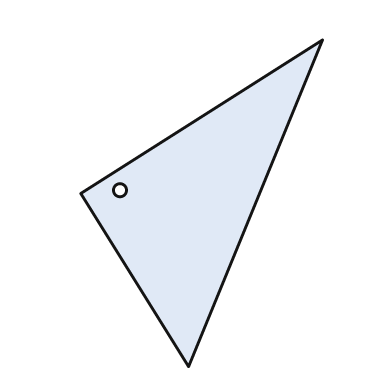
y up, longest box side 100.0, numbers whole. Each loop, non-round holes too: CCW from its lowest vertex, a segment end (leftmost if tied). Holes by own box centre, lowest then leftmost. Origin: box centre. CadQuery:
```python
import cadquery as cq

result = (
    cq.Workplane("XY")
    .moveTo(-4.0, -50.0)
    .lineTo(37.0, 50.0)
    .lineTo(-37.0, 3.0)
    .close()
    .moveTo(-25.0, 4.0)
    .circle(2.0)
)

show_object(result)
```